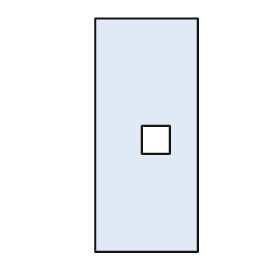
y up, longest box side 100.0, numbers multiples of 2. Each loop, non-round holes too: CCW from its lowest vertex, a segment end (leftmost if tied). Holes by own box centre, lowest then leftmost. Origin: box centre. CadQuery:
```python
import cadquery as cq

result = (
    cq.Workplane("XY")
    .moveTo(-22.0, -50.0)
    .lineTo(22.0, -50.0)
    .lineTo(22.0, 50.0)
    .lineTo(-22.0, 50.0)
    .close()
    .moveTo(-2.0, -8.0)
    .lineTo(10.0, -8.0)
    .lineTo(10.0, 4.0)
    .lineTo(-2.0, 4.0)
    .close()
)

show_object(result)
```